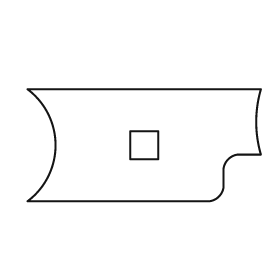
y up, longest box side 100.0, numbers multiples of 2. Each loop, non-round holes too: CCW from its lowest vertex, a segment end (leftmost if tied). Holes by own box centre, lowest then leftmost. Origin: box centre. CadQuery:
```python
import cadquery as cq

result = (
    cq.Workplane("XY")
    .moveTo(-50.0, -24.0)
    .lineTo(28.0, -24.0)
    .threePointArc((32.0, -22.0), (34.0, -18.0))
    .lineTo(34.0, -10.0)
    .threePointArc((36.0, -6.0), (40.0, -4.0))
    .lineTo(50.0, -4.0)
    .threePointArc((48.0, 10.0), (50.0, 24.0))
    .lineTo(-50.0, 24.0)
    .threePointArc((-38.0, 0.0), (-50.0, -24.0))
    .close()
    .moveTo(-6.0, -6.0)
    .lineTo(6.0, -6.0)
    .lineTo(6.0, 6.0)
    .lineTo(-6.0, 6.0)
    .close()
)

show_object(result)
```